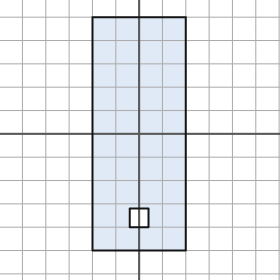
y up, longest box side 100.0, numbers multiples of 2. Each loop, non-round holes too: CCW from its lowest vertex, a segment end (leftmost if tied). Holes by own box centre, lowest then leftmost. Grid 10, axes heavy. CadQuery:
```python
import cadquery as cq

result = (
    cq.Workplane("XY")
    .moveTo(-20.0, -50.0)
    .lineTo(20.0, -50.0)
    .lineTo(20.0, 50.0)
    .lineTo(-20.0, 50.0)
    .close()
    .moveTo(-4.0, -40.0)
    .lineTo(4.0, -40.0)
    .lineTo(4.0, -32.0)
    .lineTo(-4.0, -32.0)
    .close()
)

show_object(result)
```